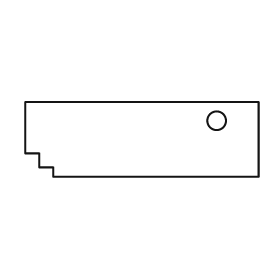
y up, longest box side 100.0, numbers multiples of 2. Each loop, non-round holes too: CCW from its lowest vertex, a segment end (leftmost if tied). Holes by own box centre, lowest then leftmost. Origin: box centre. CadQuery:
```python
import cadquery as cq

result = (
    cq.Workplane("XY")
    .moveTo(-38.0, -16.0)
    .lineTo(50.0, -16.0)
    .lineTo(50.0, 16.0)
    .lineTo(-50.0, 16.0)
    .lineTo(-50.0, -6.0)
    .lineTo(-44.0, -6.0)
    .lineTo(-44.0, -12.0)
    .lineTo(-38.0, -12.0)
    .close()
    .moveTo(32.0, 8.0)
    .circle(4.0)
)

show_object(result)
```